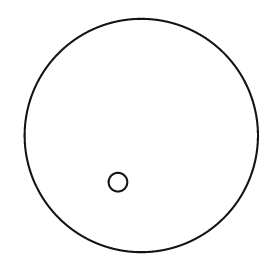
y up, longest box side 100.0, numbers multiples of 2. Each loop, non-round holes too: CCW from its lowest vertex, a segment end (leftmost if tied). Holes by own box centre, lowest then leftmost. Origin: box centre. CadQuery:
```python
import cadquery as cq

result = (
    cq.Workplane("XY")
    .moveTo(0.0, 0.0)
    .circle(50.0)
    .moveTo(-10.0, -20.0)
    .circle(4.0)
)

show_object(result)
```